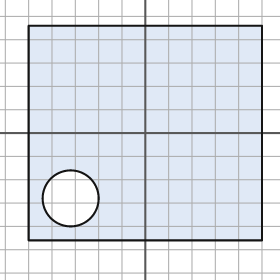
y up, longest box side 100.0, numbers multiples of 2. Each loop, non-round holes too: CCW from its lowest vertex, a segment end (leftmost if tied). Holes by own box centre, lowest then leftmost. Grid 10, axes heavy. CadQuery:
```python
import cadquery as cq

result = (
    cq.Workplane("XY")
    .moveTo(-50.0, -46.0)
    .lineTo(50.0, -46.0)
    .lineTo(50.0, 46.0)
    .lineTo(-50.0, 46.0)
    .close()
    .moveTo(-32.0, -28.0)
    .circle(12.0)
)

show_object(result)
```